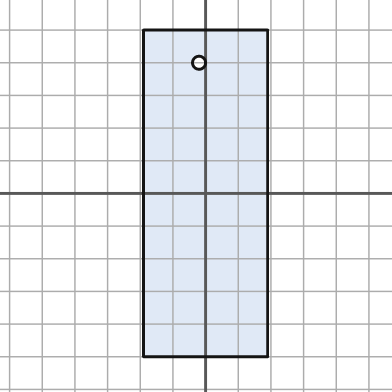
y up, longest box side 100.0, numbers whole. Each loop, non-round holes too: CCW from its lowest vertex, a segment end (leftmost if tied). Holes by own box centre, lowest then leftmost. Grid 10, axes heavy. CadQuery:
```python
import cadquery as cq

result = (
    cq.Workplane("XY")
    .moveTo(-19.0, -50.0)
    .lineTo(19.0, -50.0)
    .lineTo(19.0, 50.0)
    .lineTo(-19.0, 50.0)
    .close()
    .moveTo(-2.0, 40.0)
    .circle(2.0)
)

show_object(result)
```